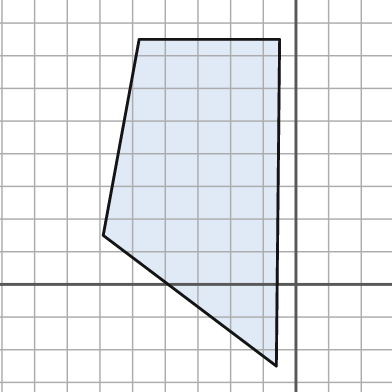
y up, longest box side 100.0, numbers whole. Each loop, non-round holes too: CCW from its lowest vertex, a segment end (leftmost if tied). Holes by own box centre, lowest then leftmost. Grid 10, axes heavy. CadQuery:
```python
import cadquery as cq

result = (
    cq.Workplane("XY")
    .moveTo(-6.0, -25.0)
    .lineTo(-5.0, 75.0)
    .lineTo(-48.0, 75.0)
    .lineTo(-59.0, 15.0)
    .close()
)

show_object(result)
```